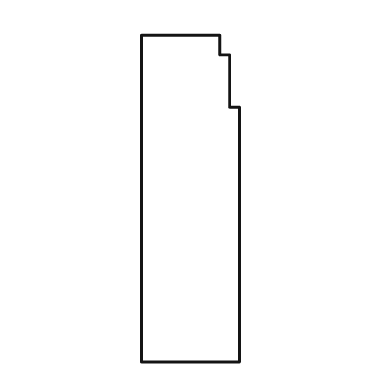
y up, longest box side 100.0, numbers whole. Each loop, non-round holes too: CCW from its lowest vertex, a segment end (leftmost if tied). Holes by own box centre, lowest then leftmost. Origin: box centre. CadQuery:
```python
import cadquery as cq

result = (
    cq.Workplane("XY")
    .moveTo(-15.0, -50.0)
    .lineTo(15.0, -50.0)
    .lineTo(15.0, 28.0)
    .lineTo(12.0, 28.0)
    .lineTo(12.0, 44.0)
    .lineTo(9.0, 44.0)
    .lineTo(9.0, 50.0)
    .lineTo(-15.0, 50.0)
    .close()
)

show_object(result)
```